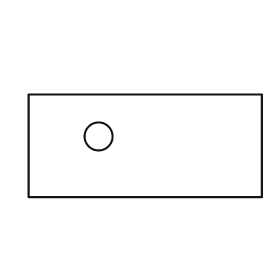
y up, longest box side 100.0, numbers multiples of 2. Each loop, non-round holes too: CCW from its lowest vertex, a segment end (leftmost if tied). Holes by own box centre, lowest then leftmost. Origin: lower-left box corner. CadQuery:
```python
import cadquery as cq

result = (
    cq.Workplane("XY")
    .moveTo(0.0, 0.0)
    .lineTo(100.0, 0.0)
    .lineTo(100.0, 44.0)
    .lineTo(0.0, 44.0)
    .close()
    .moveTo(30.0, 26.0)
    .circle(6.0)
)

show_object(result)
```